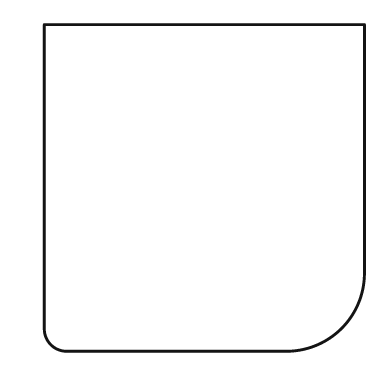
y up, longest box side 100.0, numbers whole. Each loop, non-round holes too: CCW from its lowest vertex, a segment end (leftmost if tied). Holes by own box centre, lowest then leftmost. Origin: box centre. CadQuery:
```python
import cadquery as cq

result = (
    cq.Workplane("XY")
    .moveTo(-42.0, -50.0)
    .lineTo(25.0, -50.0)
    .threePointArc((42.0, -43.0), (49.0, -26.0))
    .lineTo(49.0, 50.0)
    .lineTo(-49.0, 50.0)
    .lineTo(-49.0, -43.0)
    .threePointArc((-47.0, -48.0), (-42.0, -50.0))
    .close()
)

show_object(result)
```